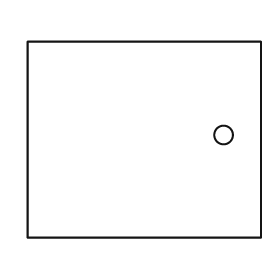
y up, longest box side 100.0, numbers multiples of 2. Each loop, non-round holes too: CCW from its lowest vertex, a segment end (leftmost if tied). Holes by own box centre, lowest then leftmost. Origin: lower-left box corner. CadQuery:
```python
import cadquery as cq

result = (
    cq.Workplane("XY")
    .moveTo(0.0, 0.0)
    .lineTo(100.0, 0.0)
    .lineTo(100.0, 84.0)
    .lineTo(0.0, 84.0)
    .close()
    .moveTo(84.0, 44.0)
    .circle(4.0)
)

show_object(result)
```